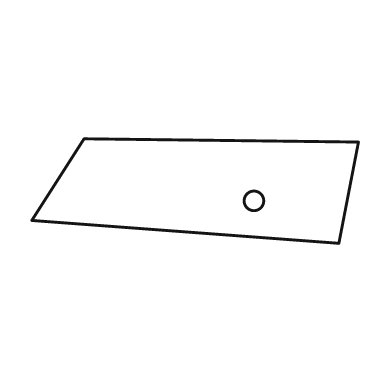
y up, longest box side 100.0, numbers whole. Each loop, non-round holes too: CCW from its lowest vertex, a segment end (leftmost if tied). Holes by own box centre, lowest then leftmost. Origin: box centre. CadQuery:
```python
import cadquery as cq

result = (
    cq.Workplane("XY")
    .moveTo(44.0, -16.0)
    .lineTo(50.0, 15.0)
    .lineTo(-34.0, 16.0)
    .lineTo(-50.0, -9.0)
    .close()
    .moveTo(18.0, -3.0)
    .circle(3.0)
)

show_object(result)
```